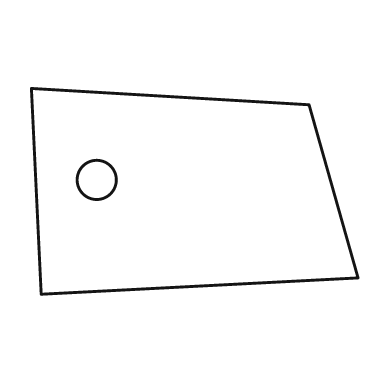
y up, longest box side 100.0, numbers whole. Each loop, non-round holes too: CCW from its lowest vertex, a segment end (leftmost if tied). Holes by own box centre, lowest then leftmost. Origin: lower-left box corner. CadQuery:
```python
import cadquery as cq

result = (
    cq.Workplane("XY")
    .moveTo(3.0, 0.0)
    .lineTo(100.0, 5.0)
    .lineTo(85.0, 58.0)
    .lineTo(0.0, 63.0)
    .close()
    .moveTo(20.0, 35.0)
    .circle(6.0)
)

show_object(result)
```